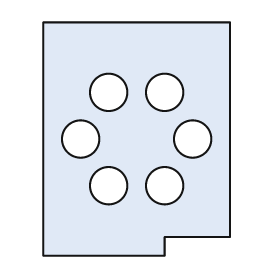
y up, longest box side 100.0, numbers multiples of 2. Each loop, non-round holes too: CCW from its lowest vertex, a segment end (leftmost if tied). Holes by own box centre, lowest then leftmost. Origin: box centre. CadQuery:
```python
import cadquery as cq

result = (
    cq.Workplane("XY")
    .moveTo(-40.0, -50.0)
    .lineTo(12.0, -50.0)
    .lineTo(12.0, -42.0)
    .lineTo(40.0, -42.0)
    .lineTo(40.0, 50.0)
    .lineTo(-40.0, 50.0)
    .close()
    .moveTo(-12.0, -20.0)
    .circle(8.0)
    .moveTo(12.0, -20.0)
    .circle(8.0)
    .moveTo(-24.0, 0.0)
    .circle(8.0)
    .moveTo(24.0, 0.0)
    .circle(8.0)
    .moveTo(-12.0, 20.0)
    .circle(8.0)
    .moveTo(12.0, 20.0)
    .circle(8.0)
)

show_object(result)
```